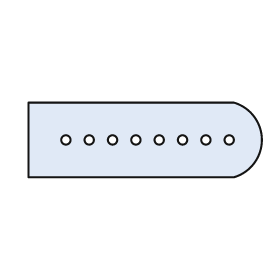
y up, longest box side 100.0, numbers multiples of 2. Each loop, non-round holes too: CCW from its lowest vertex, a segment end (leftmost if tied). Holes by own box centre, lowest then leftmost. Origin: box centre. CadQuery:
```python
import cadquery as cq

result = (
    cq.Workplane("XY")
    .moveTo(-50.0, -16.0)
    .lineTo(38.0, -16.0)
    .threePointArc((50.0, 0.0), (38.0, 16.0))
    .lineTo(-50.0, 16.0)
    .close()
    .moveTo(-34.0, 0.0)
    .circle(2.0)
    .moveTo(-24.0, 0.0)
    .circle(2.0)
    .moveTo(-14.0, 0.0)
    .circle(2.0)
    .moveTo(-4.0, 0.0)
    .circle(2.0)
    .moveTo(6.0, 0.0)
    .circle(2.0)
    .moveTo(16.0, 0.0)
    .circle(2.0)
    .moveTo(26.0, 0.0)
    .circle(2.0)
    .moveTo(36.0, 0.0)
    .circle(2.0)
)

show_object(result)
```